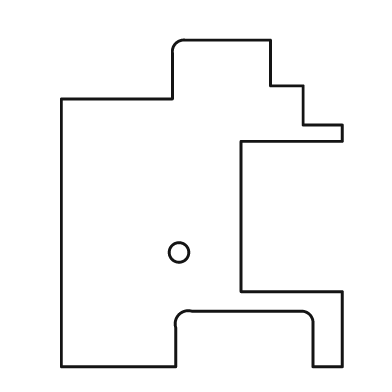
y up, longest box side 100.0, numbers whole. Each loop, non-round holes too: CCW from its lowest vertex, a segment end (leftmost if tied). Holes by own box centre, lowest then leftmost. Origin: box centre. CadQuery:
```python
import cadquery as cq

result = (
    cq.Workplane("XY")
    .moveTo(-43.0, -50.0)
    .lineTo(-8.0, -50.0)
    .lineTo(-8.0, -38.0)
    .threePointArc((-7.0, -34.0), (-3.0, -33.0))
    .lineTo(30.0, -33.0)
    .threePointArc((33.0, -34.0), (34.0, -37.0))
    .lineTo(34.0, -50.0)
    .lineTo(43.0, -50.0)
    .lineTo(43.0, -27.0)
    .lineTo(12.0, -27.0)
    .lineTo(12.0, 19.0)
    .lineTo(43.0, 19.0)
    .lineTo(43.0, 24.0)
    .lineTo(31.0, 24.0)
    .lineTo(31.0, 36.0)
    .lineTo(21.0, 36.0)
    .lineTo(21.0, 50.0)
    .lineTo(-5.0, 50.0)
    .threePointArc((-8.0, 49.0), (-9.0, 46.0))
    .lineTo(-9.0, 32.0)
    .lineTo(-43.0, 32.0)
    .close()
    .moveTo(-7.0, -15.0)
    .circle(3.0)
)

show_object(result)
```